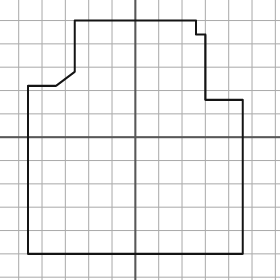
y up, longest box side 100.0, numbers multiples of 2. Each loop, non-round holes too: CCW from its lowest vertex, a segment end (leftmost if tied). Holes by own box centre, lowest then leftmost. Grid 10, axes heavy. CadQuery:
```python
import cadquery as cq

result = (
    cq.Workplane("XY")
    .moveTo(-46.0, -50.0)
    .lineTo(46.0, -50.0)
    .lineTo(46.0, 16.0)
    .lineTo(30.0, 16.0)
    .lineTo(30.0, 44.0)
    .lineTo(26.0, 44.0)
    .lineTo(26.0, 50.0)
    .lineTo(-26.0, 50.0)
    .lineTo(-26.0, 28.0)
    .lineTo(-34.0, 22.0)
    .lineTo(-46.0, 22.0)
    .close()
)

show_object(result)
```